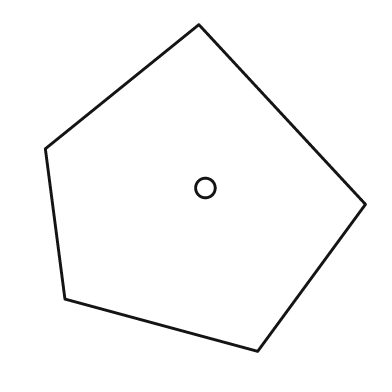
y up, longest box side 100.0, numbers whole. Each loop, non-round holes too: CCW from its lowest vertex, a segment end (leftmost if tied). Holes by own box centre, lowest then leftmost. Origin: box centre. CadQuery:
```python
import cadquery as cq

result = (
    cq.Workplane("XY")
    .moveTo(16.0, -50.0)
    .lineTo(49.0, -5.0)
    .lineTo(-2.0, 50.0)
    .lineTo(-49.0, 12.0)
    .lineTo(-43.0, -34.0)
    .close()
    .moveTo(0.0, 0.0)
    .circle(3.0)
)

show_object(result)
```